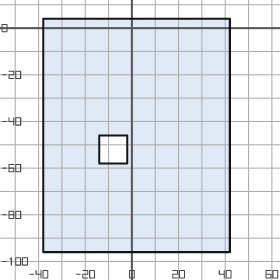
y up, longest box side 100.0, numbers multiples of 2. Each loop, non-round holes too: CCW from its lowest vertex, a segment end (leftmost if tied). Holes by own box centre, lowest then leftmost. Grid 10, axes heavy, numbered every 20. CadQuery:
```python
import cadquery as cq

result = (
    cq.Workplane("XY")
    .moveTo(-38.0, -96.0)
    .lineTo(42.0, -96.0)
    .lineTo(42.0, 4.0)
    .lineTo(-38.0, 4.0)
    .close()
    .moveTo(-14.0, -58.0)
    .lineTo(-2.0, -58.0)
    .lineTo(-2.0, -46.0)
    .lineTo(-14.0, -46.0)
    .close()
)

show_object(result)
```